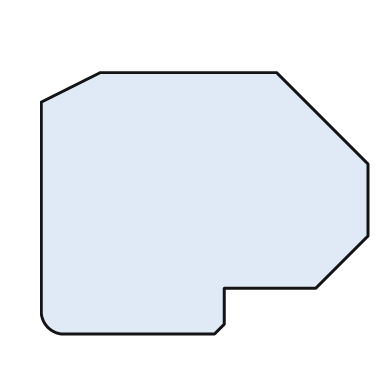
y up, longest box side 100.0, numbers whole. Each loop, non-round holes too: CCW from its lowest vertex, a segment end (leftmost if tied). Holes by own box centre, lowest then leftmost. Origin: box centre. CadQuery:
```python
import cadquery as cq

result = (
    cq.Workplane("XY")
    .moveTo(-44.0, -40.0)
    .lineTo(3.0, -40.0)
    .lineTo(6.0, -37.0)
    .lineTo(6.0, -26.0)
    .lineTo(34.0, -26.0)
    .lineTo(50.0, -10.0)
    .lineTo(50.0, 12.0)
    .lineTo(22.0, 40.0)
    .lineTo(-32.0, 40.0)
    .lineTo(-50.0, 31.0)
    .lineTo(-50.0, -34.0)
    .threePointArc((-48.0, -38.0), (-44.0, -40.0))
    .close()
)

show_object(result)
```